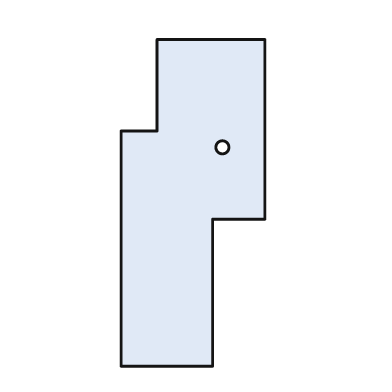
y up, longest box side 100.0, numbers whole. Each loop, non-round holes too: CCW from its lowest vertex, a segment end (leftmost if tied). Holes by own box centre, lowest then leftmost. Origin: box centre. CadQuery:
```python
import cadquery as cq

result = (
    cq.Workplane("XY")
    .moveTo(-22.0, -50.0)
    .lineTo(6.0, -50.0)
    .lineTo(6.0, -5.0)
    .lineTo(22.0, -5.0)
    .lineTo(22.0, 50.0)
    .lineTo(-11.0, 50.0)
    .lineTo(-11.0, 22.0)
    .lineTo(-22.0, 22.0)
    .close()
    .moveTo(9.0, 17.0)
    .circle(2.0)
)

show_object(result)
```